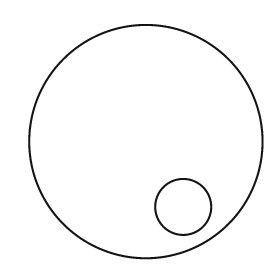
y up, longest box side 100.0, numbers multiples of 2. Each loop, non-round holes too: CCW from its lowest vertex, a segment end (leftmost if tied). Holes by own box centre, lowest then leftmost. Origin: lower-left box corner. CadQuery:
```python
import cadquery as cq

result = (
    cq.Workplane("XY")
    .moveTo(50.0, 50.0)
    .circle(50.0)
    .moveTo(66.0, 22.0)
    .circle(12.0)
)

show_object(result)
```